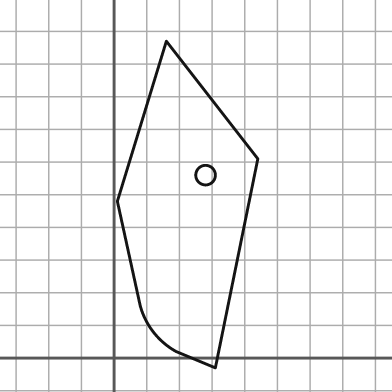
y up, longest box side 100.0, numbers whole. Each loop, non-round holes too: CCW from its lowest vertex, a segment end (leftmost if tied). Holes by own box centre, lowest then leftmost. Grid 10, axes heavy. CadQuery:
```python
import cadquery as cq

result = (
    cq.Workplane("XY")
    .moveTo(31.0, -3.0)
    .lineTo(44.0, 61.0)
    .lineTo(16.0, 97.0)
    .lineTo(1.0, 48.0)
    .lineTo(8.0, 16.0)
    .threePointArc((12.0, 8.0), (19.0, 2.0))
    .close()
    .moveTo(28.0, 56.0)
    .circle(3.0)
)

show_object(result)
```